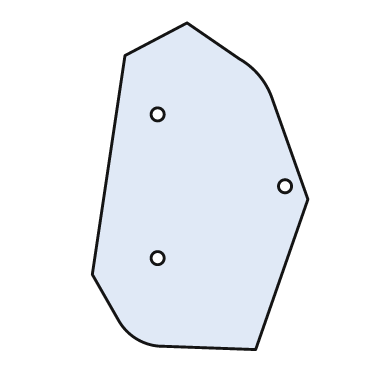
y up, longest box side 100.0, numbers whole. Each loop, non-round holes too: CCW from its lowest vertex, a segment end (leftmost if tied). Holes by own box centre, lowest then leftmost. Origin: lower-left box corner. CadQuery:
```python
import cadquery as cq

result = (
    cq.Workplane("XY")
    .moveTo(50.0, 0.0)
    .lineTo(66.0, 46.0)
    .lineTo(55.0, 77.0)
    .threePointArc((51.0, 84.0), (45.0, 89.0))
    .lineTo(29.0, 100.0)
    .lineTo(10.0, 90.0)
    .lineTo(0.0, 23.0)
    .lineTo(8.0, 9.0)
    .threePointArc((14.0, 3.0), (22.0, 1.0))
    .close()
    .moveTo(20.0, 28.0)
    .circle(2.0)
    .moveTo(59.0, 50.0)
    .circle(2.0)
    .moveTo(20.0, 72.0)
    .circle(2.0)
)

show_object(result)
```